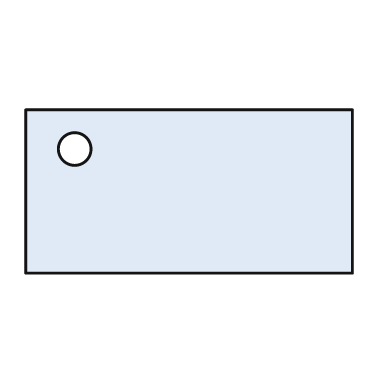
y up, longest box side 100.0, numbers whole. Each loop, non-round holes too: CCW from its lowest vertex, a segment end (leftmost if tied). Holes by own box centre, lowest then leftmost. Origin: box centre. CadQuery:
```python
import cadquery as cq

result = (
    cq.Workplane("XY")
    .moveTo(-50.0, -25.0)
    .lineTo(50.0, -25.0)
    .lineTo(50.0, 25.0)
    .lineTo(-50.0, 25.0)
    .close()
    .moveTo(-35.0, 13.0)
    .circle(5.0)
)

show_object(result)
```